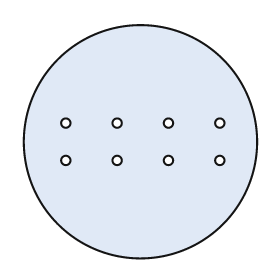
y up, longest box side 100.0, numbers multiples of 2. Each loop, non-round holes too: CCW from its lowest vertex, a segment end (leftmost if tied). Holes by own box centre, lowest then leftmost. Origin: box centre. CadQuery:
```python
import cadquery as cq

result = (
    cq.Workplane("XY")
    .moveTo(0.0, 0.0)
    .circle(50.0)
    .moveTo(-32.0, -8.0)
    .circle(2.0)
    .moveTo(-10.0, -8.0)
    .circle(2.0)
    .moveTo(12.0, -8.0)
    .circle(2.0)
    .moveTo(34.0, -8.0)
    .circle(2.0)
    .moveTo(-32.0, 8.0)
    .circle(2.0)
    .moveTo(-10.0, 8.0)
    .circle(2.0)
    .moveTo(12.0, 8.0)
    .circle(2.0)
    .moveTo(34.0, 8.0)
    .circle(2.0)
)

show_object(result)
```